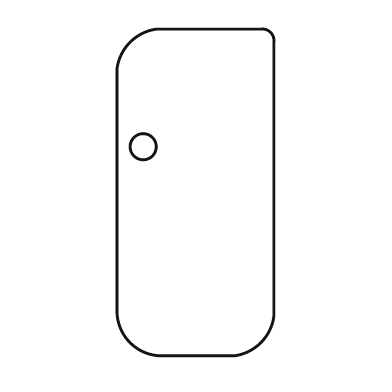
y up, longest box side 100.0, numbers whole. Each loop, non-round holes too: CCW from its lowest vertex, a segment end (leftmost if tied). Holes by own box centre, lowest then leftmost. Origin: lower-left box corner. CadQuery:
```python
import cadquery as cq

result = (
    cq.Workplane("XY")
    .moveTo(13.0, 0.0)
    .lineTo(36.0, 0.0)
    .threePointArc((44.0, 4.0), (48.0, 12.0))
    .lineTo(48.0, 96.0)
    .threePointArc((47.0, 99.0), (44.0, 100.0))
    .lineTo(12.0, 100.0)
    .threePointArc((4.0, 96.0), (0.0, 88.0))
    .lineTo(0.0, 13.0)
    .threePointArc((4.0, 4.0), (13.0, 0.0))
    .close()
    .moveTo(8.0, 64.0)
    .circle(4.0)
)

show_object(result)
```